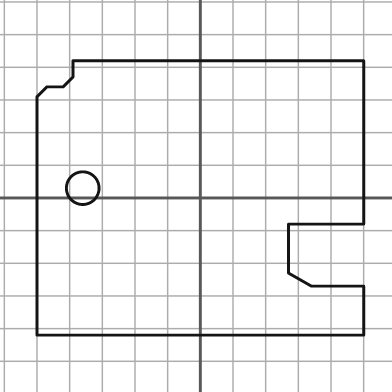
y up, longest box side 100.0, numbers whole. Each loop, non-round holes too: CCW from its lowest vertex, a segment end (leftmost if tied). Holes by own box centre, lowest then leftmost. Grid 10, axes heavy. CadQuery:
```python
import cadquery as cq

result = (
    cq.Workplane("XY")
    .moveTo(-50.0, -42.0)
    .lineTo(50.0, -42.0)
    .lineTo(50.0, -27.0)
    .lineTo(34.0, -27.0)
    .lineTo(27.0, -23.0)
    .lineTo(27.0, -8.0)
    .lineTo(50.0, -8.0)
    .lineTo(50.0, 42.0)
    .lineTo(-39.0, 42.0)
    .lineTo(-39.0, 37.0)
    .lineTo(-42.0, 34.0)
    .lineTo(-47.0, 34.0)
    .lineTo(-50.0, 31.0)
    .close()
    .moveTo(-36.0, 3.0)
    .circle(5.0)
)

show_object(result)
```